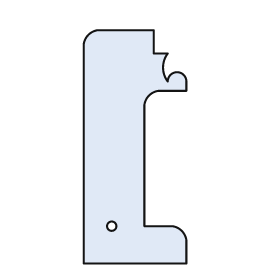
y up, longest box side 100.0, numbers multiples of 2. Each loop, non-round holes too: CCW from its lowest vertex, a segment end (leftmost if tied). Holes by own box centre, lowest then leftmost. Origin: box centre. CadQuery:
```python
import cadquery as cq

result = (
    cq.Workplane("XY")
    .moveTo(-22.0, -50.0)
    .lineTo(22.0, -50.0)
    .lineTo(22.0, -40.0)
    .threePointArc((20.0, -36.0), (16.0, -34.0))
    .lineTo(4.0, -34.0)
    .lineTo(4.0, 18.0)
    .threePointArc((6.0, 22.0), (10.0, 24.0))
    .lineTo(22.0, 24.0)
    .lineTo(22.0, 28.0)
    .threePointArc((18.0, 32.0), (14.0, 28.0))
    .threePointArc((12.0, 34.0), (14.0, 40.0))
    .lineTo(8.0, 40.0)
    .lineTo(8.0, 50.0)
    .lineTo(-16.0, 50.0)
    .threePointArc((-20.0, 48.0), (-22.0, 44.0))
    .close()
    .moveTo(-10.0, -34.0)
    .circle(2.0)
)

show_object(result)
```